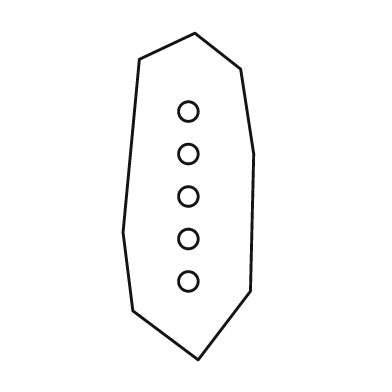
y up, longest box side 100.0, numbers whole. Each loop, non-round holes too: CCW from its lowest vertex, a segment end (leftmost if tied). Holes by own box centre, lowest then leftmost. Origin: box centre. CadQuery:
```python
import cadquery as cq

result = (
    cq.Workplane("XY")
    .moveTo(3.0, -50.0)
    .lineTo(19.0, -29.0)
    .lineTo(20.0, 13.0)
    .lineTo(16.0, 39.0)
    .lineTo(2.0, 50.0)
    .lineTo(-15.0, 42.0)
    .lineTo(-20.0, -11.0)
    .lineTo(-17.0, -35.0)
    .close()
    .moveTo(0.0, -26.0)
    .circle(3.0)
    .moveTo(0.0, -13.0)
    .circle(3.0)
    .moveTo(0.0, 0.0)
    .circle(3.0)
    .moveTo(0.0, 13.0)
    .circle(3.0)
    .moveTo(0.0, 26.0)
    .circle(3.0)
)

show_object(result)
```